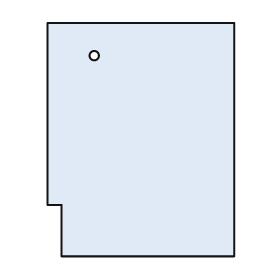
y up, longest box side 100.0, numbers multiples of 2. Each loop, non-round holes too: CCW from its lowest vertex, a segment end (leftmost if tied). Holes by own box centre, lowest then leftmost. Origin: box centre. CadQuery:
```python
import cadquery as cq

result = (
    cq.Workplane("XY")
    .moveTo(-34.0, -50.0)
    .lineTo(40.0, -50.0)
    .lineTo(40.0, 50.0)
    .lineTo(-40.0, 50.0)
    .lineTo(-40.0, -28.0)
    .lineTo(-34.0, -28.0)
    .close()
    .moveTo(-20.0, 36.0)
    .circle(2.0)
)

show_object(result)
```